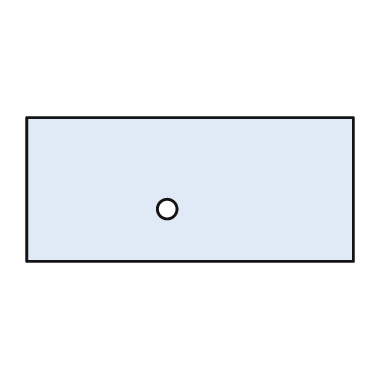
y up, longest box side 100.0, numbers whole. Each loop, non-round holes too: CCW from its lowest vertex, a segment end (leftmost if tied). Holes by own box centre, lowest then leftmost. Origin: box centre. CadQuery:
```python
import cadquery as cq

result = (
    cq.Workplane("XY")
    .moveTo(-50.0, -22.0)
    .lineTo(50.0, -22.0)
    .lineTo(50.0, 22.0)
    .lineTo(-50.0, 22.0)
    .close()
    .moveTo(-7.0, -6.0)
    .circle(3.0)
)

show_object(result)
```